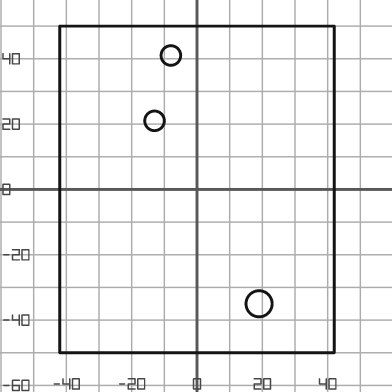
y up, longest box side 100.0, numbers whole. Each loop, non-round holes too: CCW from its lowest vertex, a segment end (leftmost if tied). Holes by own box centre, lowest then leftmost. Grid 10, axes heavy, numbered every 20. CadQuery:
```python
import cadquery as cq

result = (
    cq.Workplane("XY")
    .moveTo(-42.0, -50.0)
    .lineTo(42.0, -50.0)
    .lineTo(42.0, 50.0)
    .lineTo(-42.0, 50.0)
    .close()
    .moveTo(19.0, -35.0)
    .circle(4.0)
    .moveTo(-13.0, 21.0)
    .circle(3.0)
    .moveTo(-8.0, 41.0)
    .circle(3.0)
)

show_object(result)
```